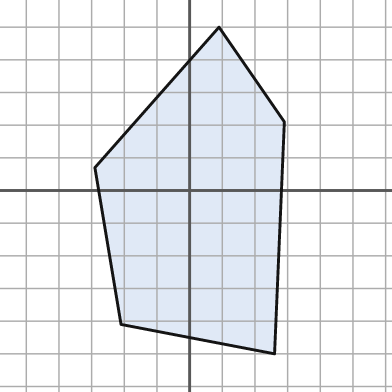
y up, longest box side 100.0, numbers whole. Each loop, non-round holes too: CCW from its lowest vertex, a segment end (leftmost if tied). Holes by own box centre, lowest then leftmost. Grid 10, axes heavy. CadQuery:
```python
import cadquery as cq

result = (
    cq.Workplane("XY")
    .moveTo(26.0, -50.0)
    .lineTo(29.0, 21.0)
    .lineTo(9.0, 50.0)
    .lineTo(-29.0, 7.0)
    .lineTo(-21.0, -41.0)
    .close()
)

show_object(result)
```